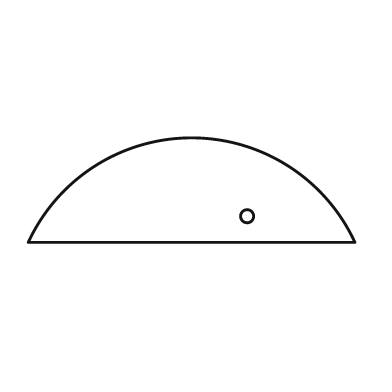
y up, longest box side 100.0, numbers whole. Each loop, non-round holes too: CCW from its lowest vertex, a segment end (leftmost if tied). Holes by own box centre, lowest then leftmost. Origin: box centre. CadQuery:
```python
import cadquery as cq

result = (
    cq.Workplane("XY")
    .moveTo(-50.0, -16.0)
    .lineTo(50.0, -16.0)
    .threePointArc((0.0, 16.0), (-50.0, -16.0))
    .close()
    .moveTo(17.0, -8.0)
    .circle(2.0)
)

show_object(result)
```